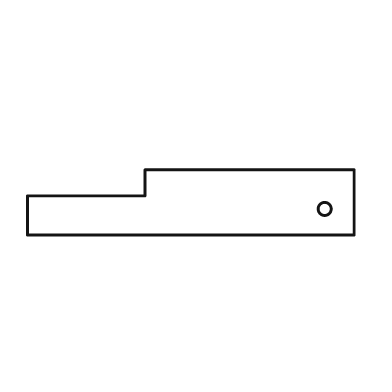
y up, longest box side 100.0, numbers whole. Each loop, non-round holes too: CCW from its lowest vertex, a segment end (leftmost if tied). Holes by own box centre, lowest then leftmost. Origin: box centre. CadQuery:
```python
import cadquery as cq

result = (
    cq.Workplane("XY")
    .moveTo(-50.0, -10.0)
    .lineTo(50.0, -10.0)
    .lineTo(50.0, 10.0)
    .lineTo(-14.0, 10.0)
    .lineTo(-14.0, 2.0)
    .lineTo(-50.0, 2.0)
    .close()
    .moveTo(41.0, -2.0)
    .circle(2.0)
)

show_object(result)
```